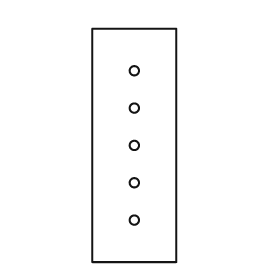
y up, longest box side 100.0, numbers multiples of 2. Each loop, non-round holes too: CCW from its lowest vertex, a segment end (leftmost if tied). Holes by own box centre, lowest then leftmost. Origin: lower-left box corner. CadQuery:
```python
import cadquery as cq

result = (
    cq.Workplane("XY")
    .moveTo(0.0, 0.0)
    .lineTo(36.0, 0.0)
    .lineTo(36.0, 100.0)
    .lineTo(0.0, 100.0)
    .close()
    .moveTo(18.0, 18.0)
    .circle(2.0)
    .moveTo(18.0, 34.0)
    .circle(2.0)
    .moveTo(18.0, 50.0)
    .circle(2.0)
    .moveTo(18.0, 66.0)
    .circle(2.0)
    .moveTo(18.0, 82.0)
    .circle(2.0)
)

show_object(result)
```